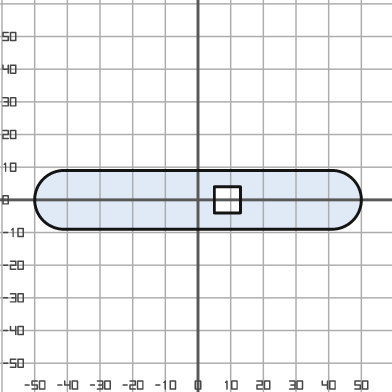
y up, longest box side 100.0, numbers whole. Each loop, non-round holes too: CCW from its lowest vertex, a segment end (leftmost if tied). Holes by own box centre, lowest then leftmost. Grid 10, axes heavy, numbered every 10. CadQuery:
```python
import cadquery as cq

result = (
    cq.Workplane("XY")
    .moveTo(-41.0, -9.0)
    .lineTo(41.0, -9.0)
    .threePointArc((50.0, 0.0), (41.0, 9.0))
    .lineTo(-41.0, 9.0)
    .threePointArc((-50.0, 0.0), (-41.0, -9.0))
    .close()
    .moveTo(5.0, -4.0)
    .lineTo(13.0, -4.0)
    .lineTo(13.0, 4.0)
    .lineTo(5.0, 4.0)
    .close()
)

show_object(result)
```